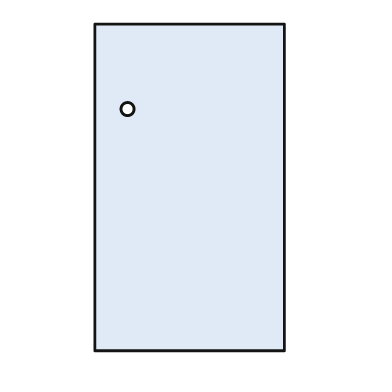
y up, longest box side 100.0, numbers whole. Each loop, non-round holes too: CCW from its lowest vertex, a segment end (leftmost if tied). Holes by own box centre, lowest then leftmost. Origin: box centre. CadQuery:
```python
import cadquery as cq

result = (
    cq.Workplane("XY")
    .moveTo(-29.0, -50.0)
    .lineTo(29.0, -50.0)
    .lineTo(29.0, 50.0)
    .lineTo(-29.0, 50.0)
    .close()
    .moveTo(-19.0, 24.0)
    .circle(2.0)
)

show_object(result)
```